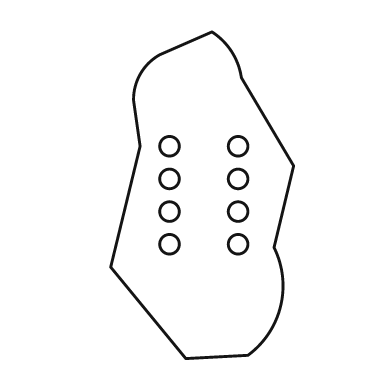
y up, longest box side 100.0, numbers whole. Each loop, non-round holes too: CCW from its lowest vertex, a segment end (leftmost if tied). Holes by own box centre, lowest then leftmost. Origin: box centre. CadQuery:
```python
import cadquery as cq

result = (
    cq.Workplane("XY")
    .moveTo(-5.0, -50.0)
    .lineTo(14.0, -49.0)
    .threePointArc((24.0, -34.0), (22.0, -16.0))
    .lineTo(28.0, 9.0)
    .lineTo(12.0, 36.0)
    .threePointArc((9.0, 44.0), (3.0, 50.0))
    .lineTo(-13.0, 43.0)
    .threePointArc((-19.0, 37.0), (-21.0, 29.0))
    .lineTo(-19.0, 15.0)
    .lineTo(-28.0, -22.0)
    .close()
    .moveTo(-10.0, -15.0)
    .circle(3.0)
    .moveTo(11.0, -15.0)
    .circle(3.0)
    .moveTo(-10.0, -5.0)
    .circle(3.0)
    .moveTo(11.0, -5.0)
    .circle(3.0)
    .moveTo(-10.0, 5.0)
    .circle(3.0)
    .moveTo(11.0, 5.0)
    .circle(3.0)
    .moveTo(-10.0, 15.0)
    .circle(3.0)
    .moveTo(11.0, 15.0)
    .circle(3.0)
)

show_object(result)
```